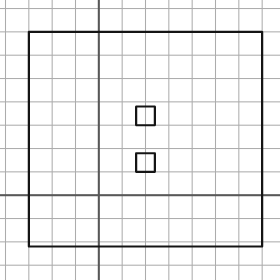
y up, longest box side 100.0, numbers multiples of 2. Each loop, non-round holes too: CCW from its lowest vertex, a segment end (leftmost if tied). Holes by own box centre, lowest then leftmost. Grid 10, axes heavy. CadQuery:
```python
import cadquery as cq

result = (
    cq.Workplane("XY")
    .moveTo(-30.0, -22.0)
    .lineTo(70.0, -22.0)
    .lineTo(70.0, 70.0)
    .lineTo(-30.0, 70.0)
    .close()
    .moveTo(16.0, 10.0)
    .lineTo(24.0, 10.0)
    .lineTo(24.0, 18.0)
    .lineTo(16.0, 18.0)
    .close()
    .moveTo(16.0, 30.0)
    .lineTo(24.0, 30.0)
    .lineTo(24.0, 38.0)
    .lineTo(16.0, 38.0)
    .close()
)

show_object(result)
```